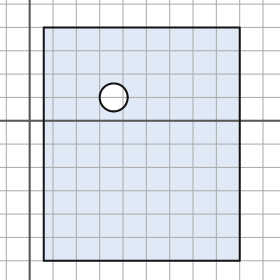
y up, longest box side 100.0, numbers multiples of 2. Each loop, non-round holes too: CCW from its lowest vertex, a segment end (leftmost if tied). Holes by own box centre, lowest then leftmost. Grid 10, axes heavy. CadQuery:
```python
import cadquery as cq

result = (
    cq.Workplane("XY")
    .moveTo(6.0, -60.0)
    .lineTo(90.0, -60.0)
    .lineTo(90.0, 40.0)
    .lineTo(6.0, 40.0)
    .close()
    .moveTo(36.0, 10.0)
    .circle(6.0)
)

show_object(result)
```